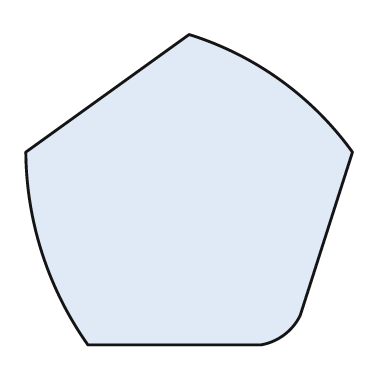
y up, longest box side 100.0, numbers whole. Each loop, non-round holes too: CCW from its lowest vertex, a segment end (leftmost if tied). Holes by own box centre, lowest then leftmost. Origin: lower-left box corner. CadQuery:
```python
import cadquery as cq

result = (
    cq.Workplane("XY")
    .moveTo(19.0, 0.0)
    .lineTo(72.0, 0.0)
    .threePointArc((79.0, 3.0), (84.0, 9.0))
    .lineTo(100.0, 59.0)
    .threePointArc((78.0, 81.0), (50.0, 95.0))
    .lineTo(0.0, 59.0)
    .threePointArc((5.0, 28.0), (19.0, 0.0))
    .close()
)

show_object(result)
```